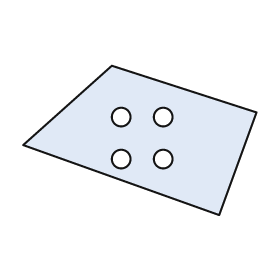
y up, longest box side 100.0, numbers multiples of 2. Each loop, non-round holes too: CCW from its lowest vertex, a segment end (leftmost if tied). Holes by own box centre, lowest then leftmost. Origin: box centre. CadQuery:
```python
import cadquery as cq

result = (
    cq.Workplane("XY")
    .moveTo(34.0, -32.0)
    .lineTo(50.0, 12.0)
    .lineTo(-12.0, 32.0)
    .lineTo(-50.0, -2.0)
    .close()
    .moveTo(-8.0, -8.0)
    .circle(4.0)
    .moveTo(10.0, -8.0)
    .circle(4.0)
    .moveTo(-8.0, 10.0)
    .circle(4.0)
    .moveTo(10.0, 10.0)
    .circle(4.0)
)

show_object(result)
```